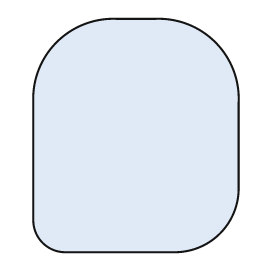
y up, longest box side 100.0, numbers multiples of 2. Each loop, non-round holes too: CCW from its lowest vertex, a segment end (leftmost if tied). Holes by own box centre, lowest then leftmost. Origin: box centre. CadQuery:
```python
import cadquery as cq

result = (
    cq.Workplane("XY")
    .moveTo(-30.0, -50.0)
    .lineTo(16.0, -50.0)
    .threePointArc((36.0, -42.0), (44.0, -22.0))
    .lineTo(44.0, 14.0)
    .threePointArc((34.0, 40.0), (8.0, 50.0))
    .lineTo(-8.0, 50.0)
    .threePointArc((-34.0, 40.0), (-44.0, 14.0))
    .lineTo(-44.0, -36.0)
    .threePointArc((-40.0, -46.0), (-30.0, -50.0))
    .close()
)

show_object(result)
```